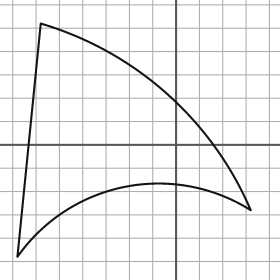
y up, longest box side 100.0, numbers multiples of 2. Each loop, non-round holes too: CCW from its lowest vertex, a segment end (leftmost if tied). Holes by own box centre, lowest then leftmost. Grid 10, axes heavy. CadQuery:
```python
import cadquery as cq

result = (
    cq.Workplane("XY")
    .moveTo(-68.0, -48.0)
    .threePointArc((-22.0, -18.0), (32.0, -28.0))
    .threePointArc((-4.0, 22.0), (-58.0, 52.0))
    .close()
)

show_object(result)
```